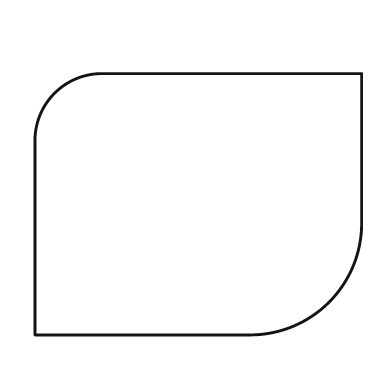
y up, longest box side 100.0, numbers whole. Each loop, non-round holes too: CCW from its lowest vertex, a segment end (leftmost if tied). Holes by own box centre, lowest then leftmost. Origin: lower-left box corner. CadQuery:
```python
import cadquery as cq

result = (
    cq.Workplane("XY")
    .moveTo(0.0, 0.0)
    .lineTo(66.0, 0.0)
    .threePointArc((90.0, 10.0), (100.0, 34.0))
    .lineTo(100.0, 80.0)
    .lineTo(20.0, 80.0)
    .threePointArc((6.0, 74.0), (0.0, 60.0))
    .close()
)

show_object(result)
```